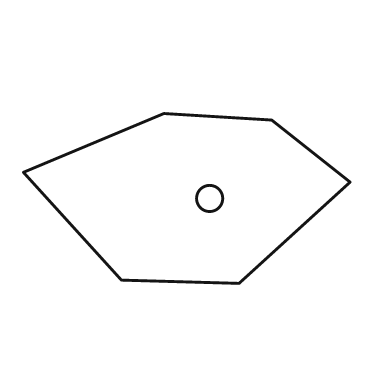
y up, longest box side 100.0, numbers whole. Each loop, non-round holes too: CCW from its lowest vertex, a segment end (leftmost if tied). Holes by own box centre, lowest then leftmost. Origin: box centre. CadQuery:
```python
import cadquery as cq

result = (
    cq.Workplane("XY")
    .moveTo(16.0, -26.0)
    .lineTo(50.0, 5.0)
    .lineTo(26.0, 24.0)
    .lineTo(-7.0, 26.0)
    .lineTo(-50.0, 8.0)
    .lineTo(-20.0, -25.0)
    .close()
    .moveTo(7.0, 0.0)
    .circle(4.0)
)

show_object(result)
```